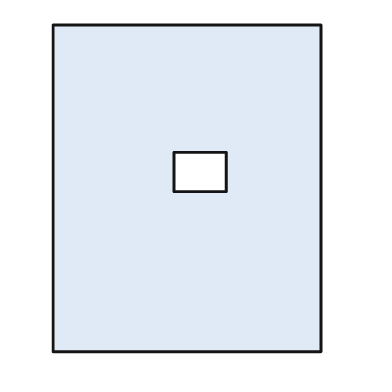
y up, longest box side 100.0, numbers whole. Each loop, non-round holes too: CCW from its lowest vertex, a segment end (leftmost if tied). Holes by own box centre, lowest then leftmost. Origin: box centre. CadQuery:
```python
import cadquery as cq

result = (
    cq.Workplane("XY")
    .moveTo(-41.0, -50.0)
    .lineTo(41.0, -50.0)
    .lineTo(41.0, 50.0)
    .lineTo(-41.0, 50.0)
    .close()
    .moveTo(-4.0, -1.0)
    .lineTo(12.0, -1.0)
    .lineTo(12.0, 11.0)
    .lineTo(-4.0, 11.0)
    .close()
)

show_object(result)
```